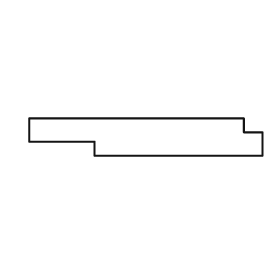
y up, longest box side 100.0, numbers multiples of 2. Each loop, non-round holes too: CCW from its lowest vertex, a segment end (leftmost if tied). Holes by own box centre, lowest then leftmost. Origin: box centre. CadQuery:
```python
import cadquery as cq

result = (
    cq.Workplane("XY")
    .moveTo(-22.0, -8.0)
    .lineTo(50.0, -8.0)
    .lineTo(50.0, 2.0)
    .lineTo(42.0, 2.0)
    .lineTo(42.0, 8.0)
    .lineTo(-50.0, 8.0)
    .lineTo(-50.0, -2.0)
    .lineTo(-22.0, -2.0)
    .close()
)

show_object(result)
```